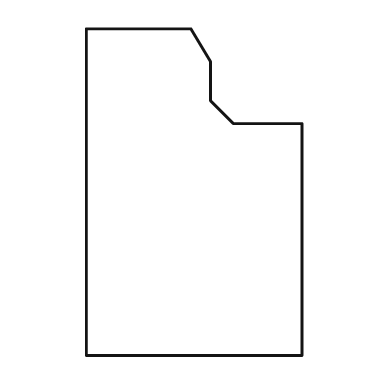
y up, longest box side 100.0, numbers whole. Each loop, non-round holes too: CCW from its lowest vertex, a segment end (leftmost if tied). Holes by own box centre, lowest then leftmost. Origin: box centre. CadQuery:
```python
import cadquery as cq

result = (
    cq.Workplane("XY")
    .moveTo(-33.0, -50.0)
    .lineTo(33.0, -50.0)
    .lineTo(33.0, 21.0)
    .lineTo(12.0, 21.0)
    .lineTo(5.0, 28.0)
    .lineTo(5.0, 40.0)
    .lineTo(-1.0, 50.0)
    .lineTo(-33.0, 50.0)
    .close()
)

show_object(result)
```